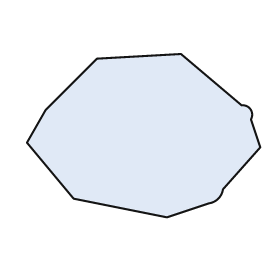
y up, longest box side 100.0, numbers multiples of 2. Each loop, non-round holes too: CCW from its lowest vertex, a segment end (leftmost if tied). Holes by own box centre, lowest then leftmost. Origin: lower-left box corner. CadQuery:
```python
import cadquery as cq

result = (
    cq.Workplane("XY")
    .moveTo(60.0, 0.0)
    .lineTo(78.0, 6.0)
    .threePointArc((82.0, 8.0), (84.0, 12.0))
    .lineTo(100.0, 30.0)
    .lineTo(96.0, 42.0)
    .threePointArc((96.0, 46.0), (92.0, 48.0))
    .lineTo(66.0, 70.0)
    .lineTo(30.0, 68.0)
    .lineTo(8.0, 46.0)
    .lineTo(0.0, 32.0)
    .lineTo(20.0, 8.0)
    .close()
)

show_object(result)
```